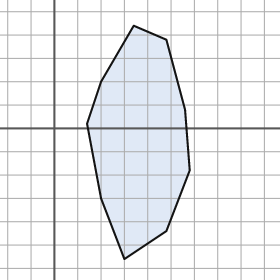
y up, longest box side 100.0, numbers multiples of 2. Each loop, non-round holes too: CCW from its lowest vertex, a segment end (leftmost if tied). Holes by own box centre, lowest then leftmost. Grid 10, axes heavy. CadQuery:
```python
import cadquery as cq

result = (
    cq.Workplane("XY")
    .moveTo(30.0, -56.0)
    .lineTo(48.0, -44.0)
    .lineTo(58.0, -18.0)
    .lineTo(56.0, 8.0)
    .lineTo(48.0, 38.0)
    .lineTo(34.0, 44.0)
    .lineTo(20.0, 20.0)
    .lineTo(14.0, 2.0)
    .lineTo(20.0, -30.0)
    .close()
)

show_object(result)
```